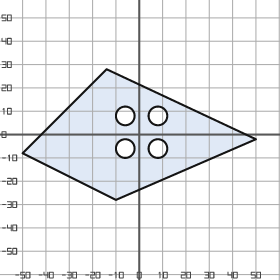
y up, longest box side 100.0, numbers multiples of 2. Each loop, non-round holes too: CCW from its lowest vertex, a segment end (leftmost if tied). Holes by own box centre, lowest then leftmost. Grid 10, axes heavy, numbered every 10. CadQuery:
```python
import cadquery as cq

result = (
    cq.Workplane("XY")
    .moveTo(-10.0, -28.0)
    .lineTo(50.0, -2.0)
    .lineTo(-14.0, 28.0)
    .lineTo(-50.0, -8.0)
    .close()
    .moveTo(-6.0, -6.0)
    .circle(4.0)
    .moveTo(8.0, -6.0)
    .circle(4.0)
    .moveTo(-6.0, 8.0)
    .circle(4.0)
    .moveTo(8.0, 8.0)
    .circle(4.0)
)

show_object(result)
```